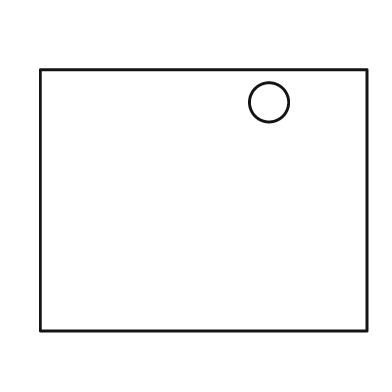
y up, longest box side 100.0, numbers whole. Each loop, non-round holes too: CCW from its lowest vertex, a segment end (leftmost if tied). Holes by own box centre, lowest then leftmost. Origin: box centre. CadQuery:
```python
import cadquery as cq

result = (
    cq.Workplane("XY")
    .moveTo(-50.0, -40.0)
    .lineTo(50.0, -40.0)
    .lineTo(50.0, 40.0)
    .lineTo(-50.0, 40.0)
    .close()
    .moveTo(20.0, 30.0)
    .circle(6.0)
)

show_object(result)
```